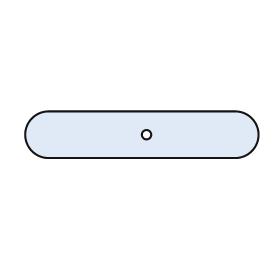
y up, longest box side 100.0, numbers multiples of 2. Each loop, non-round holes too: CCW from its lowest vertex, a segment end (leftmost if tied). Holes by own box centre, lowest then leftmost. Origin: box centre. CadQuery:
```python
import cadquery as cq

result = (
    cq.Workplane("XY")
    .moveTo(-40.0, -10.0)
    .lineTo(40.0, -10.0)
    .threePointArc((50.0, 0.0), (40.0, 10.0))
    .lineTo(-40.0, 10.0)
    .threePointArc((-50.0, 0.0), (-40.0, -10.0))
    .close()
    .moveTo(2.0, 0.0)
    .circle(2.0)
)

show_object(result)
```